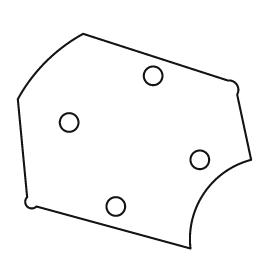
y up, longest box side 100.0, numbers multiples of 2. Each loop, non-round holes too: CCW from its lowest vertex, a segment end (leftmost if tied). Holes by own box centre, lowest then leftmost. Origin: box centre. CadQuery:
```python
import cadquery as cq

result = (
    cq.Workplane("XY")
    .moveTo(24.0, -46.0)
    .threePointArc((30.0, -22.0), (50.0, -8.0))
    .lineTo(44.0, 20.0)
    .threePointArc((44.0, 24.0), (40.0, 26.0))
    .lineTo(-22.0, 46.0)
    .threePointArc((-38.0, 34.0), (-50.0, 18.0))
    .lineTo(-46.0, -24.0)
    .threePointArc((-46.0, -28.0), (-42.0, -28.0))
    .close()
    .moveTo(-8.0, -28.0)
    .circle(4.0)
    .moveTo(28.0, -8.0)
    .circle(4.0)
    .moveTo(-28.0, 8.0)
    .circle(4.0)
    .moveTo(8.0, 28.0)
    .circle(4.0)
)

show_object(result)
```